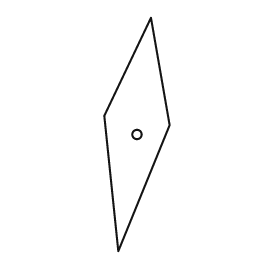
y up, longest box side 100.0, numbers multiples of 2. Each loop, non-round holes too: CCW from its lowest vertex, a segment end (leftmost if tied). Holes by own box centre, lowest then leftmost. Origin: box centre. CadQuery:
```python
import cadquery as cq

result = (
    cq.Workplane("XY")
    .moveTo(-8.0, -50.0)
    .lineTo(14.0, 4.0)
    .lineTo(6.0, 50.0)
    .lineTo(-14.0, 8.0)
    .close()
    .moveTo(0.0, 0.0)
    .circle(2.0)
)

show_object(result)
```